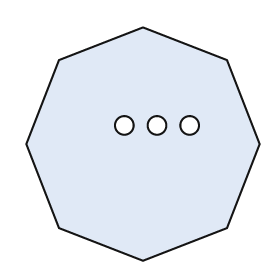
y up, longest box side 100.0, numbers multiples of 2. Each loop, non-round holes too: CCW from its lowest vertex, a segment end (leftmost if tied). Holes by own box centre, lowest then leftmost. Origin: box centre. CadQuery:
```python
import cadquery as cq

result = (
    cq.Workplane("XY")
    .moveTo(0.0, -50.0)
    .lineTo(36.0, -36.0)
    .lineTo(50.0, 0.0)
    .lineTo(36.0, 36.0)
    .lineTo(0.0, 50.0)
    .lineTo(-36.0, 36.0)
    .lineTo(-50.0, 0.0)
    .lineTo(-36.0, -36.0)
    .close()
    .moveTo(-8.0, 8.0)
    .circle(4.0)
    .moveTo(6.0, 8.0)
    .circle(4.0)
    .moveTo(20.0, 8.0)
    .circle(4.0)
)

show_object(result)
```